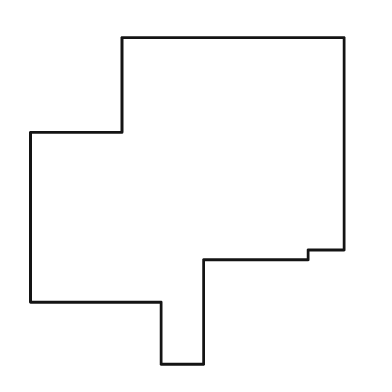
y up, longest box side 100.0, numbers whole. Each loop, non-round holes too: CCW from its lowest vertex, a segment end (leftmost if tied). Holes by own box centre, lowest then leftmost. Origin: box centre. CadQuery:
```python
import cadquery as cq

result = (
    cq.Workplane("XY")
    .moveTo(-8.0, -50.0)
    .lineTo(5.0, -50.0)
    .lineTo(5.0, -18.0)
    .lineTo(37.0, -18.0)
    .lineTo(37.0, -15.0)
    .lineTo(48.0, -15.0)
    .lineTo(48.0, 50.0)
    .lineTo(-20.0, 50.0)
    .lineTo(-20.0, 21.0)
    .lineTo(-48.0, 21.0)
    .lineTo(-48.0, -31.0)
    .lineTo(-8.0, -31.0)
    .close()
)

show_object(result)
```